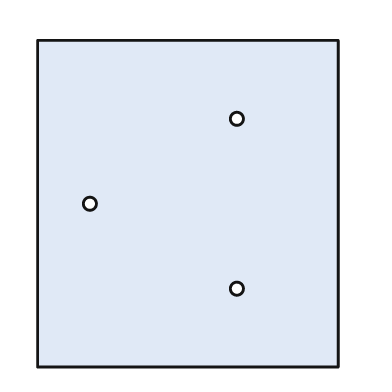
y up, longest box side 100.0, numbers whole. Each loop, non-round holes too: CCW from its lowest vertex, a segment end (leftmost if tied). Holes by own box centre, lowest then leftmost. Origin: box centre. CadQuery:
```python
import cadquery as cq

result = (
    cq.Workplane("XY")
    .moveTo(-46.0, -50.0)
    .lineTo(46.0, -50.0)
    .lineTo(46.0, 50.0)
    .lineTo(-46.0, 50.0)
    .close()
    .moveTo(15.0, -26.0)
    .circle(2.0)
    .moveTo(-30.0, 0.0)
    .circle(2.0)
    .moveTo(15.0, 26.0)
    .circle(2.0)
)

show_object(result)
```